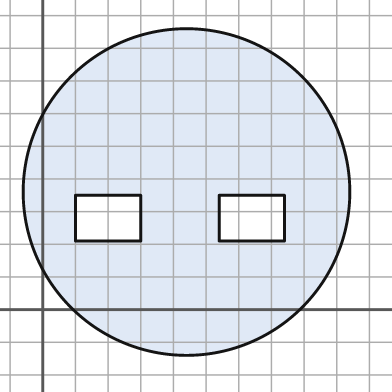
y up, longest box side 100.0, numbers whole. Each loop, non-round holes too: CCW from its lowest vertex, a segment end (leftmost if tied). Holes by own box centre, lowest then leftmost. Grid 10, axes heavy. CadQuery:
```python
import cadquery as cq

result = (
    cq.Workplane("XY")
    .moveTo(44.0, 36.0)
    .circle(50.0)
    .moveTo(10.0, 21.0)
    .lineTo(30.0, 21.0)
    .lineTo(30.0, 35.0)
    .lineTo(10.0, 35.0)
    .close()
    .moveTo(54.0, 21.0)
    .lineTo(74.0, 21.0)
    .lineTo(74.0, 35.0)
    .lineTo(54.0, 35.0)
    .close()
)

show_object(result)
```